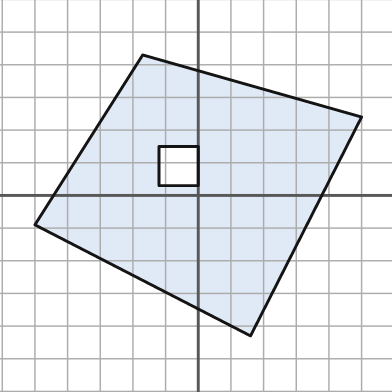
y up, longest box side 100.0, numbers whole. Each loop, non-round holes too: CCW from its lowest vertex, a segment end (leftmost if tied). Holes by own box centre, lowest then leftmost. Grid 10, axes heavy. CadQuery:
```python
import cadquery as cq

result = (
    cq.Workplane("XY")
    .moveTo(16.0, -43.0)
    .lineTo(50.0, 24.0)
    .lineTo(-17.0, 43.0)
    .lineTo(-50.0, -9.0)
    .close()
    .moveTo(-12.0, 3.0)
    .lineTo(0.0, 3.0)
    .lineTo(0.0, 15.0)
    .lineTo(-12.0, 15.0)
    .close()
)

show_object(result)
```